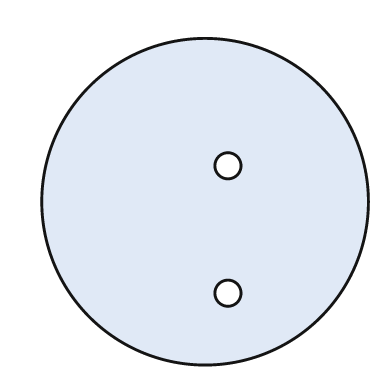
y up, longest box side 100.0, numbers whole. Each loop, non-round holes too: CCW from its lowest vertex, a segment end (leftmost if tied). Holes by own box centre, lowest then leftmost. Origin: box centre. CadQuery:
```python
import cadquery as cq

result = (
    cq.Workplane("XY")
    .moveTo(0.0, 0.0)
    .circle(50.0)
    .moveTo(7.0, -28.0)
    .circle(4.0)
    .moveTo(7.0, 11.0)
    .circle(4.0)
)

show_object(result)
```